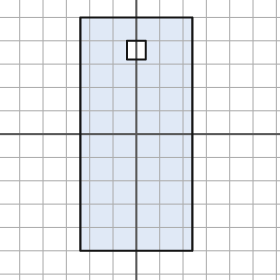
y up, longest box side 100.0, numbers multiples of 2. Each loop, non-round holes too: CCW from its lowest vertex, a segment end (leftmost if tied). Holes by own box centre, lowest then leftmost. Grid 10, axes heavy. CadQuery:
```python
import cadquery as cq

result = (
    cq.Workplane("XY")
    .moveTo(-24.0, -50.0)
    .lineTo(24.0, -50.0)
    .lineTo(24.0, 50.0)
    .lineTo(-24.0, 50.0)
    .close()
    .moveTo(-4.0, 32.0)
    .lineTo(4.0, 32.0)
    .lineTo(4.0, 40.0)
    .lineTo(-4.0, 40.0)
    .close()
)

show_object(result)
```